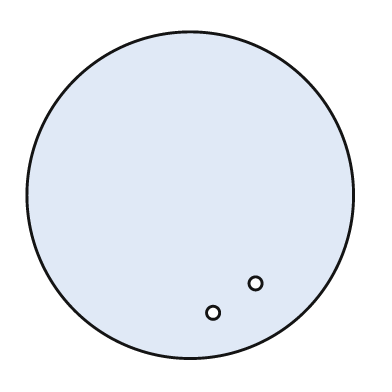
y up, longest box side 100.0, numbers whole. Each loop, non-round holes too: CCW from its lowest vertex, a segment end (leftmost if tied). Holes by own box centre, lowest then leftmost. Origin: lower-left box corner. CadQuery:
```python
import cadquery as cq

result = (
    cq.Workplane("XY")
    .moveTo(50.0, 50.0)
    .circle(50.0)
    .moveTo(57.0, 14.0)
    .circle(2.0)
    .moveTo(70.0, 23.0)
    .circle(2.0)
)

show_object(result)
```